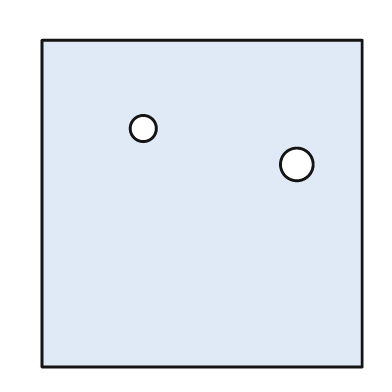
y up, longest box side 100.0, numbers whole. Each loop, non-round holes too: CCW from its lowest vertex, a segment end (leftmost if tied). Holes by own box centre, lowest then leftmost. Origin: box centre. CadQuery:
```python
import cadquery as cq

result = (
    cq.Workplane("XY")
    .moveTo(-49.0, -50.0)
    .lineTo(49.0, -50.0)
    .lineTo(49.0, 50.0)
    .lineTo(-49.0, 50.0)
    .close()
    .moveTo(29.0, 12.0)
    .circle(5.0)
    .moveTo(-18.0, 23.0)
    .circle(4.0)
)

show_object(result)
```